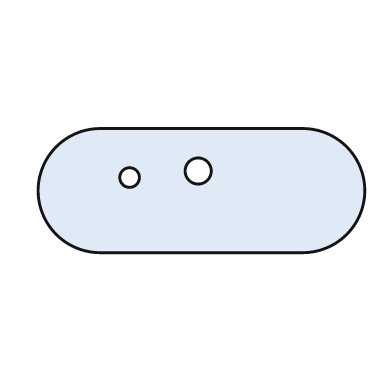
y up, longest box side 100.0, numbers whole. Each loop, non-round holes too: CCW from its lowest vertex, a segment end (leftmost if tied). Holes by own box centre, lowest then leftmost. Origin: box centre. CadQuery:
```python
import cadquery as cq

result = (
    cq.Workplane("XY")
    .moveTo(-31.0, -19.0)
    .lineTo(31.0, -19.0)
    .threePointArc((50.0, 0.0), (31.0, 19.0))
    .lineTo(-31.0, 19.0)
    .threePointArc((-50.0, 0.0), (-31.0, -19.0))
    .close()
    .moveTo(-22.0, 4.0)
    .circle(3.0)
    .moveTo(-1.0, 6.0)
    .circle(4.0)
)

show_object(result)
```